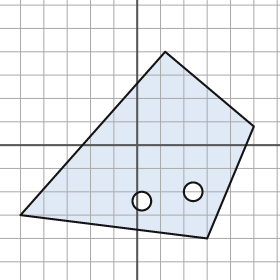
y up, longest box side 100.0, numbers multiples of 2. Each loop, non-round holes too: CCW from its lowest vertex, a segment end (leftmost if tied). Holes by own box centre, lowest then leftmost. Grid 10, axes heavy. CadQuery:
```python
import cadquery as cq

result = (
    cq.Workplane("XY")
    .moveTo(30.0, -40.0)
    .lineTo(50.0, 8.0)
    .lineTo(12.0, 40.0)
    .lineTo(-50.0, -30.0)
    .close()
    .moveTo(2.0, -24.0)
    .circle(4.0)
    .moveTo(24.0, -20.0)
    .circle(4.0)
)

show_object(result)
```